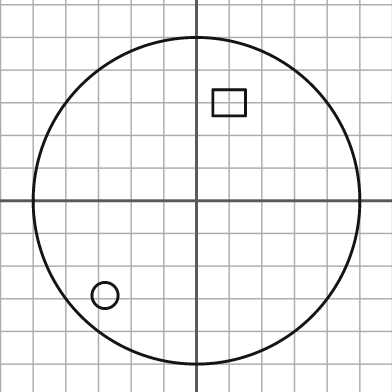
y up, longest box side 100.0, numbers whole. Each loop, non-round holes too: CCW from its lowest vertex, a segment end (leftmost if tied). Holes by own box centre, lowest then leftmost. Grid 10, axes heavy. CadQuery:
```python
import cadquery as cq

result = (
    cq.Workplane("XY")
    .moveTo(0.0, 0.0)
    .circle(50.0)
    .moveTo(-28.0, -29.0)
    .circle(4.0)
    .moveTo(5.0, 26.0)
    .lineTo(15.0, 26.0)
    .lineTo(15.0, 34.0)
    .lineTo(5.0, 34.0)
    .close()
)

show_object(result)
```